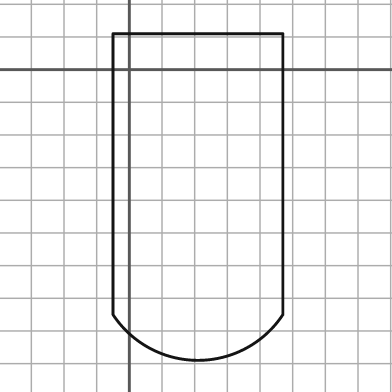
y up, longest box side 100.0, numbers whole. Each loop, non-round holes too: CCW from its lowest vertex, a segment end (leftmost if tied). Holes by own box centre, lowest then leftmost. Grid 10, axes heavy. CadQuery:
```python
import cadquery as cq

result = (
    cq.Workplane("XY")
    .moveTo(-5.0, -75.0)
    .threePointArc((21.0, -89.0), (47.0, -75.0))
    .lineTo(47.0, 11.0)
    .lineTo(-5.0, 11.0)
    .close()
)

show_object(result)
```